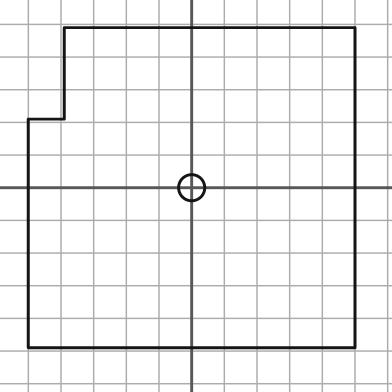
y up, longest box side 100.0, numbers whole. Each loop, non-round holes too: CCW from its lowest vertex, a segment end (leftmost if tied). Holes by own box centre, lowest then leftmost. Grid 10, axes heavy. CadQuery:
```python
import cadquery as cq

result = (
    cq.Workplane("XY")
    .moveTo(-50.0, -49.0)
    .lineTo(50.0, -49.0)
    .lineTo(50.0, 49.0)
    .lineTo(-39.0, 49.0)
    .lineTo(-39.0, 21.0)
    .lineTo(-50.0, 21.0)
    .close()
    .moveTo(0.0, 0.0)
    .circle(4.0)
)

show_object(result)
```